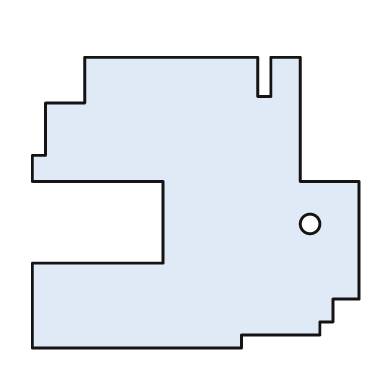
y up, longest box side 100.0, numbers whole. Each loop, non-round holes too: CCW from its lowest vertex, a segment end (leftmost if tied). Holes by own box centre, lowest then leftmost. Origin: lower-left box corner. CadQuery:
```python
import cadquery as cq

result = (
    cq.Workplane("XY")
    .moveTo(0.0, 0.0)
    .lineTo(64.0, 0.0)
    .lineTo(64.0, 4.0)
    .lineTo(88.0, 4.0)
    .lineTo(88.0, 8.0)
    .lineTo(92.0, 8.0)
    .lineTo(92.0, 15.0)
    .lineTo(100.0, 15.0)
    .lineTo(100.0, 51.0)
    .lineTo(82.0, 51.0)
    .lineTo(82.0, 89.0)
    .lineTo(73.0, 89.0)
    .lineTo(73.0, 77.0)
    .lineTo(69.0, 77.0)
    .lineTo(69.0, 89.0)
    .lineTo(16.0, 89.0)
    .lineTo(16.0, 75.0)
    .lineTo(4.0, 75.0)
    .lineTo(4.0, 59.0)
    .lineTo(0.0, 59.0)
    .lineTo(0.0, 51.0)
    .lineTo(40.0, 51.0)
    .lineTo(40.0, 26.0)
    .lineTo(0.0, 26.0)
    .close()
    .moveTo(85.0, 38.0)
    .circle(3.0)
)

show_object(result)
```